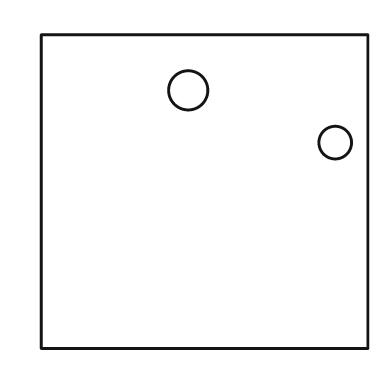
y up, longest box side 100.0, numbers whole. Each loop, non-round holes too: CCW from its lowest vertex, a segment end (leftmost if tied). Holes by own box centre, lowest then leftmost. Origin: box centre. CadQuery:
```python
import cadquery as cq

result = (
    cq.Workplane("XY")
    .moveTo(-50.0, -48.0)
    .lineTo(50.0, -48.0)
    .lineTo(50.0, 48.0)
    .lineTo(-50.0, 48.0)
    .close()
    .moveTo(40.0, 15.0)
    .circle(5.0)
    .moveTo(-5.0, 31.0)
    .circle(6.0)
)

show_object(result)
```